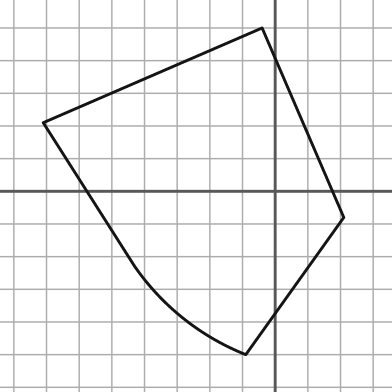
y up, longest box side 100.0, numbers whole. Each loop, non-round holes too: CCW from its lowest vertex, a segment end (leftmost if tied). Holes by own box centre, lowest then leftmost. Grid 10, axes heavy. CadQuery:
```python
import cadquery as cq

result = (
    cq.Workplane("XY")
    .moveTo(-9.0, -50.0)
    .lineTo(21.0, -8.0)
    .lineTo(-4.0, 50.0)
    .lineTo(-71.0, 21.0)
    .lineTo(-43.0, -23.0)
    .threePointArc((-28.0, -39.0), (-9.0, -50.0))
    .close()
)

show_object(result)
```